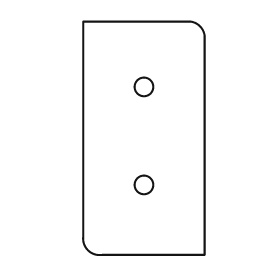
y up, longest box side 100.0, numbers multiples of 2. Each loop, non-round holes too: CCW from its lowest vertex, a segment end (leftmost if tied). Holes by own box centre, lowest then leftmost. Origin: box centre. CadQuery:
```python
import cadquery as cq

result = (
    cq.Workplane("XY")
    .moveTo(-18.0, -50.0)
    .lineTo(26.0, -50.0)
    .lineTo(26.0, 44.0)
    .threePointArc((24.0, 48.0), (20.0, 50.0))
    .lineTo(-26.0, 50.0)
    .lineTo(-26.0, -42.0)
    .threePointArc((-24.0, -48.0), (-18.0, -50.0))
    .close()
    .moveTo(0.0, -20.0)
    .circle(4.0)
    .moveTo(0.0, 22.0)
    .circle(4.0)
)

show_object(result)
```